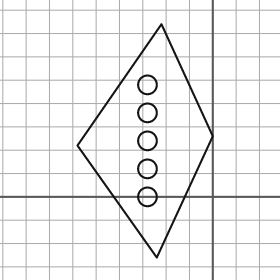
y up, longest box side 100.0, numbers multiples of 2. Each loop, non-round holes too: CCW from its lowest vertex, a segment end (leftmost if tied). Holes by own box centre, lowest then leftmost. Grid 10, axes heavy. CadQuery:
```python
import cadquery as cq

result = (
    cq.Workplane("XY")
    .moveTo(-24.0, -26.0)
    .lineTo(0.0, 26.0)
    .lineTo(-22.0, 74.0)
    .lineTo(-58.0, 22.0)
    .close()
    .moveTo(-28.0, 0.0)
    .circle(4.0)
    .moveTo(-28.0, 12.0)
    .circle(4.0)
    .moveTo(-28.0, 24.0)
    .circle(4.0)
    .moveTo(-28.0, 36.0)
    .circle(4.0)
    .moveTo(-28.0, 48.0)
    .circle(4.0)
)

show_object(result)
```